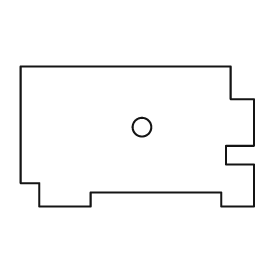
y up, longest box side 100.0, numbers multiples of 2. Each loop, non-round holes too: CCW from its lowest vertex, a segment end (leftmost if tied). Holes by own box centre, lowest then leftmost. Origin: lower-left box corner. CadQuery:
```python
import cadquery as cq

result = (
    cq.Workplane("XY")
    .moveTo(8.0, 0.0)
    .lineTo(30.0, 0.0)
    .lineTo(30.0, 6.0)
    .lineTo(86.0, 6.0)
    .lineTo(86.0, 0.0)
    .lineTo(100.0, 0.0)
    .lineTo(100.0, 18.0)
    .lineTo(88.0, 18.0)
    .lineTo(88.0, 26.0)
    .lineTo(100.0, 26.0)
    .lineTo(100.0, 46.0)
    .lineTo(90.0, 46.0)
    .lineTo(90.0, 60.0)
    .lineTo(0.0, 60.0)
    .lineTo(0.0, 10.0)
    .lineTo(8.0, 10.0)
    .close()
    .moveTo(52.0, 34.0)
    .circle(4.0)
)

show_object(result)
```